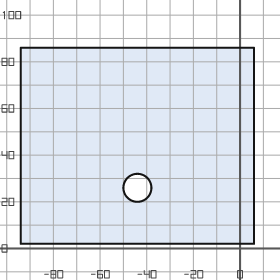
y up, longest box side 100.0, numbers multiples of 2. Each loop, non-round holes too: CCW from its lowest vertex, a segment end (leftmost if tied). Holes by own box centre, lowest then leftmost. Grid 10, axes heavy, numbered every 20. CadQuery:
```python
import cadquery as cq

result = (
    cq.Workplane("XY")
    .moveTo(-94.0, 2.0)
    .lineTo(6.0, 2.0)
    .lineTo(6.0, 86.0)
    .lineTo(-94.0, 86.0)
    .close()
    .moveTo(-44.0, 26.0)
    .circle(6.0)
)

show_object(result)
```